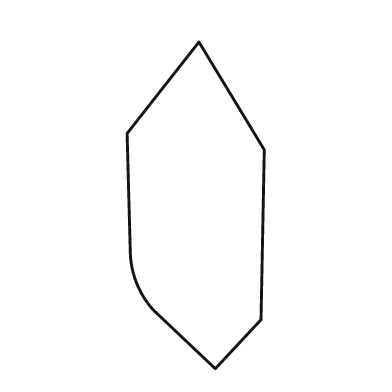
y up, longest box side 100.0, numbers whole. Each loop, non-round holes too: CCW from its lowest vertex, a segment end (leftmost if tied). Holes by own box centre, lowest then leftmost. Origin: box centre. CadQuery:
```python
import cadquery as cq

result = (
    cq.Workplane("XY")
    .moveTo(6.0, -50.0)
    .lineTo(20.0, -35.0)
    .lineTo(21.0, 17.0)
    .lineTo(1.0, 50.0)
    .lineTo(-21.0, 22.0)
    .lineTo(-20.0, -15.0)
    .threePointArc((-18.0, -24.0), (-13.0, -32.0))
    .close()
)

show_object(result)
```